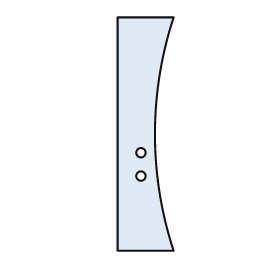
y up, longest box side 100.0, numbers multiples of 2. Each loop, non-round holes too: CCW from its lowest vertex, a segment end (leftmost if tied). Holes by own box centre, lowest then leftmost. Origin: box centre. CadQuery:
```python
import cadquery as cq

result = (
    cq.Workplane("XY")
    .moveTo(-12.0, -50.0)
    .lineTo(12.0, -50.0)
    .threePointArc((4.0, 0.0), (12.0, 50.0))
    .lineTo(-12.0, 50.0)
    .close()
    .moveTo(-2.0, -18.0)
    .circle(2.0)
    .moveTo(-2.0, -8.0)
    .circle(2.0)
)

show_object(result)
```